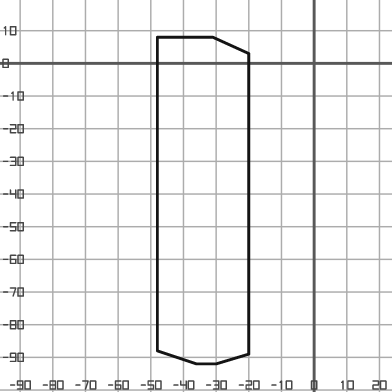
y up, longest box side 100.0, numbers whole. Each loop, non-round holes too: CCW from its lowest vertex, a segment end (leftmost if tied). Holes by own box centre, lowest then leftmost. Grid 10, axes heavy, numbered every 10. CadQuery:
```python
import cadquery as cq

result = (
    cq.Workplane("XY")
    .moveTo(-36.0, -92.0)
    .lineTo(-30.0, -92.0)
    .lineTo(-20.0, -89.0)
    .lineTo(-20.0, 3.0)
    .lineTo(-31.0, 8.0)
    .lineTo(-48.0, 8.0)
    .lineTo(-48.0, -88.0)
    .close()
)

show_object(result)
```